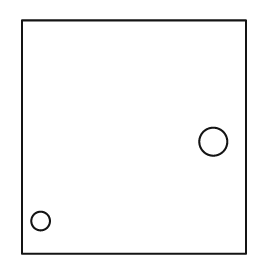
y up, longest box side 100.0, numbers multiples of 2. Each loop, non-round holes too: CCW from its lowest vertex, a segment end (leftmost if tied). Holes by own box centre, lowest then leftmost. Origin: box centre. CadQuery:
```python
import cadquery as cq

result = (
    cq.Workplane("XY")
    .moveTo(-48.0, -50.0)
    .lineTo(48.0, -50.0)
    .lineTo(48.0, 50.0)
    .lineTo(-48.0, 50.0)
    .close()
    .moveTo(-40.0, -36.0)
    .circle(4.0)
    .moveTo(34.0, -2.0)
    .circle(6.0)
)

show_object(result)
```